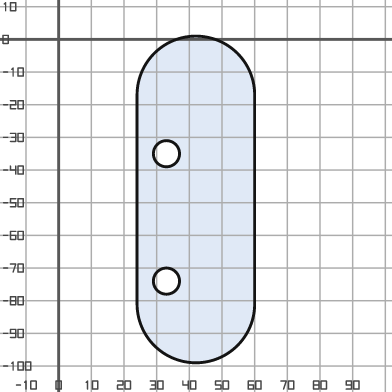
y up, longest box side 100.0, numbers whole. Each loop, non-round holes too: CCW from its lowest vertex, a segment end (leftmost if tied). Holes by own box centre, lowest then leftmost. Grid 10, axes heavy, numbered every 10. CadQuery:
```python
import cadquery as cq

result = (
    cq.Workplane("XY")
    .moveTo(24.0, -81.0)
    .threePointArc((42.0, -99.0), (60.0, -81.0))
    .lineTo(60.0, -17.0)
    .threePointArc((42.0, 1.0), (24.0, -17.0))
    .close()
    .moveTo(33.0, -74.0)
    .circle(4.0)
    .moveTo(33.0, -35.0)
    .circle(4.0)
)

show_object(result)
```